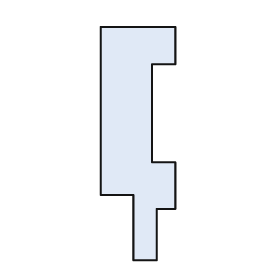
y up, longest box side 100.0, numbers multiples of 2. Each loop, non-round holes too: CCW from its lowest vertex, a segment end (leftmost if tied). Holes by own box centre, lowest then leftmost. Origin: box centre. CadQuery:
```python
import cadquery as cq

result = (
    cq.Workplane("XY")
    .moveTo(-2.0, -50.0)
    .lineTo(8.0, -50.0)
    .lineTo(8.0, -28.0)
    .lineTo(16.0, -28.0)
    .lineTo(16.0, -8.0)
    .lineTo(6.0, -8.0)
    .lineTo(6.0, 34.0)
    .lineTo(16.0, 34.0)
    .lineTo(16.0, 50.0)
    .lineTo(-16.0, 50.0)
    .lineTo(-16.0, -22.0)
    .lineTo(-2.0, -22.0)
    .close()
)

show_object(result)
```